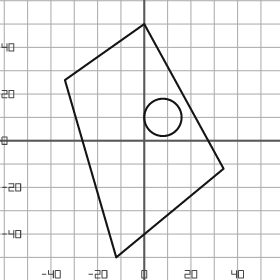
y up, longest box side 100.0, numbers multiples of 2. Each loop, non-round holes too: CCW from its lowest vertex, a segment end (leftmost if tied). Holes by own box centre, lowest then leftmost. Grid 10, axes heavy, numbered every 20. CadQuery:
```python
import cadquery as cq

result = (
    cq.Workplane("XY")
    .moveTo(-12.0, -50.0)
    .lineTo(34.0, -12.0)
    .lineTo(0.0, 50.0)
    .lineTo(-34.0, 26.0)
    .close()
    .moveTo(8.0, 10.0)
    .circle(8.0)
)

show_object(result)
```